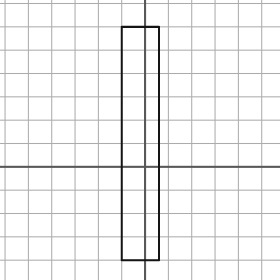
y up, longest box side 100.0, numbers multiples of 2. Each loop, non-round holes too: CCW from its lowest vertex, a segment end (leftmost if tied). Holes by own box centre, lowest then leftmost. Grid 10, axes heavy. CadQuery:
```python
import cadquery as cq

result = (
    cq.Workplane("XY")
    .moveTo(-10.0, -40.0)
    .lineTo(6.0, -40.0)
    .lineTo(6.0, 60.0)
    .lineTo(-10.0, 60.0)
    .close()
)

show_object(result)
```